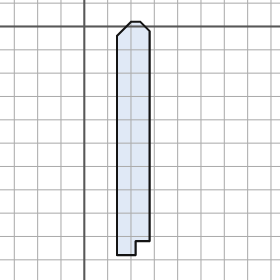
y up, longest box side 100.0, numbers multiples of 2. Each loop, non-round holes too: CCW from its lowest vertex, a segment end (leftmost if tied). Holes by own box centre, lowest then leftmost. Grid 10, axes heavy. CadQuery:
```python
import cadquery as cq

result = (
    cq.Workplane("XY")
    .moveTo(14.0, -98.0)
    .lineTo(22.0, -98.0)
    .lineTo(22.0, -92.0)
    .lineTo(28.0, -92.0)
    .lineTo(28.0, -2.0)
    .lineTo(24.0, 2.0)
    .lineTo(20.0, 2.0)
    .lineTo(14.0, -4.0)
    .close()
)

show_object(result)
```